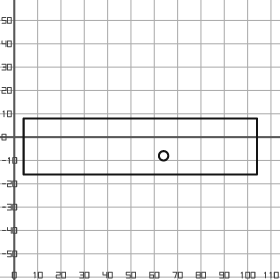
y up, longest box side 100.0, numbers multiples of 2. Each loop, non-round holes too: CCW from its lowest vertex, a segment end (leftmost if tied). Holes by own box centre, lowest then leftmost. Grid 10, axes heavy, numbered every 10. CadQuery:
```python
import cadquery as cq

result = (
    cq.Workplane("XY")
    .moveTo(4.0, -16.0)
    .lineTo(104.0, -16.0)
    .lineTo(104.0, 8.0)
    .lineTo(4.0, 8.0)
    .close()
    .moveTo(64.0, -8.0)
    .circle(2.0)
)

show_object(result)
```